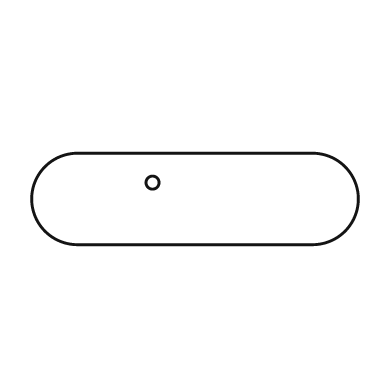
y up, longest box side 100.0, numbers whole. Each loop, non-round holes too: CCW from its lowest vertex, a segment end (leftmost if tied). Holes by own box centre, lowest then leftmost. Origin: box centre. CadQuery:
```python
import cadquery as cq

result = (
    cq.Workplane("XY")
    .moveTo(-36.0, -14.0)
    .lineTo(36.0, -14.0)
    .threePointArc((50.0, 0.0), (36.0, 14.0))
    .lineTo(-36.0, 14.0)
    .threePointArc((-50.0, 0.0), (-36.0, -14.0))
    .close()
    .moveTo(-13.0, 5.0)
    .circle(2.0)
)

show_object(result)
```